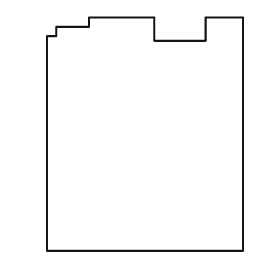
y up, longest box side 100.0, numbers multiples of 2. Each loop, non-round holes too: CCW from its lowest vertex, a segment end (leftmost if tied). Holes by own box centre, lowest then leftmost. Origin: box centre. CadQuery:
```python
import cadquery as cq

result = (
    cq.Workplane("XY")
    .moveTo(-42.0, -50.0)
    .lineTo(42.0, -50.0)
    .lineTo(42.0, 50.0)
    .lineTo(26.0, 50.0)
    .lineTo(26.0, 40.0)
    .lineTo(4.0, 40.0)
    .lineTo(4.0, 50.0)
    .lineTo(-24.0, 50.0)
    .lineTo(-24.0, 46.0)
    .lineTo(-38.0, 46.0)
    .lineTo(-38.0, 42.0)
    .lineTo(-42.0, 42.0)
    .close()
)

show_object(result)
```